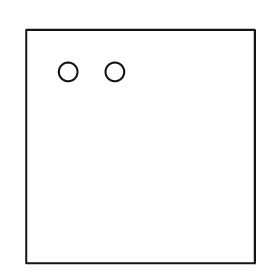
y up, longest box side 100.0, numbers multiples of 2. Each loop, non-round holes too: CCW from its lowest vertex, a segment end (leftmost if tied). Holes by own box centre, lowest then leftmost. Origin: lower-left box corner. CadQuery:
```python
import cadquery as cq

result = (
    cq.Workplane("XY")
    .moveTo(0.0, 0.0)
    .lineTo(98.0, 0.0)
    .lineTo(98.0, 100.0)
    .lineTo(0.0, 100.0)
    .close()
    .moveTo(18.0, 82.0)
    .circle(4.0)
    .moveTo(38.0, 82.0)
    .circle(4.0)
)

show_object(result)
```